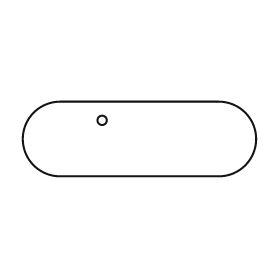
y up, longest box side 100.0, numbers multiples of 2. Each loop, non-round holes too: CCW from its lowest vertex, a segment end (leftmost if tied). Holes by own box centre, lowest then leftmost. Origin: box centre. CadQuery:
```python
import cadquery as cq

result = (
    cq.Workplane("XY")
    .moveTo(-34.0, -16.0)
    .lineTo(34.0, -16.0)
    .threePointArc((50.0, 0.0), (34.0, 16.0))
    .lineTo(-34.0, 16.0)
    .threePointArc((-50.0, 0.0), (-34.0, -16.0))
    .close()
    .moveTo(-16.0, 8.0)
    .circle(2.0)
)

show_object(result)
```